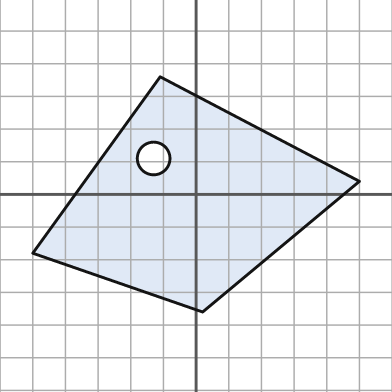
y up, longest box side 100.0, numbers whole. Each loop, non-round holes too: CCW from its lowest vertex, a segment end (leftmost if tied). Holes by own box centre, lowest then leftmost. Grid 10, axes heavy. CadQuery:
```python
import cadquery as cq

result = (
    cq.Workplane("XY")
    .moveTo(2.0, -36.0)
    .lineTo(50.0, 4.0)
    .lineTo(-11.0, 36.0)
    .lineTo(-50.0, -18.0)
    .close()
    .moveTo(-13.0, 11.0)
    .circle(5.0)
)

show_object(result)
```